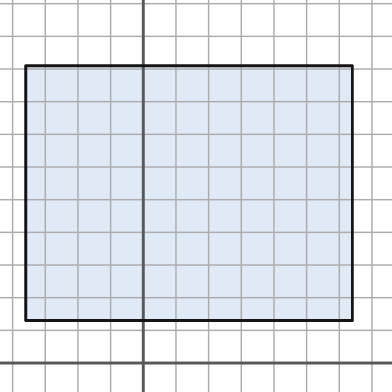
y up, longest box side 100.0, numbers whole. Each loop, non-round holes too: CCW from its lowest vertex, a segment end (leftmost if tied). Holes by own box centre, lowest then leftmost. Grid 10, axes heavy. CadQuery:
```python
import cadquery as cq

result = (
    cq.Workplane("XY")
    .moveTo(-36.0, 13.0)
    .lineTo(64.0, 13.0)
    .lineTo(64.0, 91.0)
    .lineTo(-36.0, 91.0)
    .close()
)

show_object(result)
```